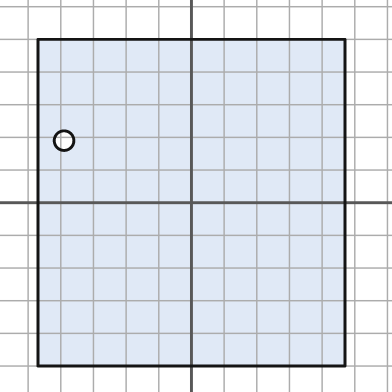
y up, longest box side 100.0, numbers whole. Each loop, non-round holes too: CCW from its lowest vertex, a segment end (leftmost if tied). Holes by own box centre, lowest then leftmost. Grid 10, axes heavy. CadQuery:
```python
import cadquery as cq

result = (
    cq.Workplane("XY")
    .moveTo(-47.0, -50.0)
    .lineTo(47.0, -50.0)
    .lineTo(47.0, 50.0)
    .lineTo(-47.0, 50.0)
    .close()
    .moveTo(-39.0, 19.0)
    .circle(3.0)
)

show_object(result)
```